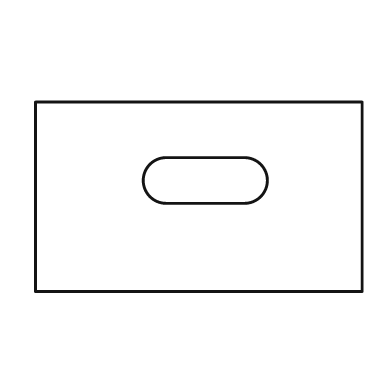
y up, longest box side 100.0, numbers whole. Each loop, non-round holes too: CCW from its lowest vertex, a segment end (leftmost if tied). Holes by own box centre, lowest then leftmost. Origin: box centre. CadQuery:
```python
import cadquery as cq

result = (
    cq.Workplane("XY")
    .moveTo(-50.0, -29.0)
    .lineTo(50.0, -29.0)
    .lineTo(50.0, 29.0)
    .lineTo(-50.0, 29.0)
    .close()
    .moveTo(-10.0, -2.0)
    .lineTo(14.0, -2.0)
    .threePointArc((21.0, 5.0), (14.0, 12.0))
    .lineTo(-10.0, 12.0)
    .threePointArc((-17.0, 5.0), (-10.0, -2.0))
    .close()
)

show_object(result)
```